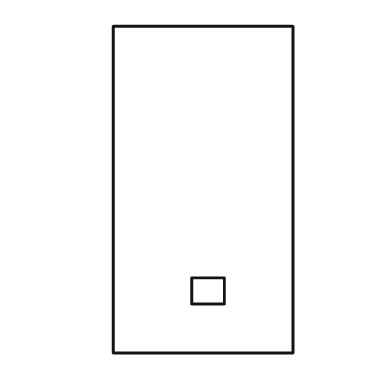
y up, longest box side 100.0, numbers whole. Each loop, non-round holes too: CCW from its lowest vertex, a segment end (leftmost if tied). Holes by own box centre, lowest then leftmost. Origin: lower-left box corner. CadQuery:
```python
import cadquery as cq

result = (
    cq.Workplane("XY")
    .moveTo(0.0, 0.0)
    .lineTo(55.0, 0.0)
    .lineTo(55.0, 100.0)
    .lineTo(0.0, 100.0)
    .close()
    .moveTo(24.0, 15.0)
    .lineTo(34.0, 15.0)
    .lineTo(34.0, 23.0)
    .lineTo(24.0, 23.0)
    .close()
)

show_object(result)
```